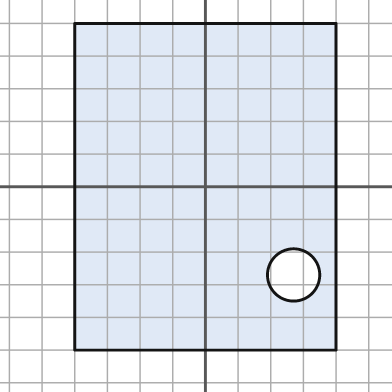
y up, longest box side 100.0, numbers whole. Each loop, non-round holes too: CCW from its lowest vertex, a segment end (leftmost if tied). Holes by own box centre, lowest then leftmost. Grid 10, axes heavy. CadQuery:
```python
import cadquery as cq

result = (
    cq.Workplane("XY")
    .moveTo(-40.0, -50.0)
    .lineTo(40.0, -50.0)
    .lineTo(40.0, 50.0)
    .lineTo(-40.0, 50.0)
    .close()
    .moveTo(27.0, -27.0)
    .circle(8.0)
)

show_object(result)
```